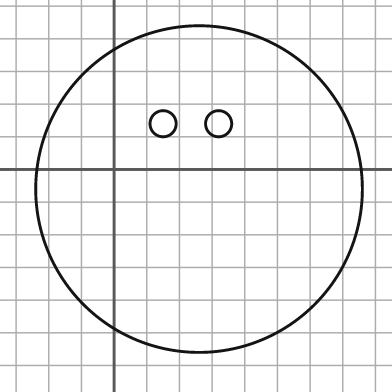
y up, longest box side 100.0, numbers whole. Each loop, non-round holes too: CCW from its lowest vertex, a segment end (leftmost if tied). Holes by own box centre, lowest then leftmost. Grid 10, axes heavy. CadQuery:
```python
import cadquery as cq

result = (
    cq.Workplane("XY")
    .moveTo(26.0, -6.0)
    .circle(50.0)
    .moveTo(15.0, 14.0)
    .circle(4.0)
    .moveTo(32.0, 14.0)
    .circle(4.0)
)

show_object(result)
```